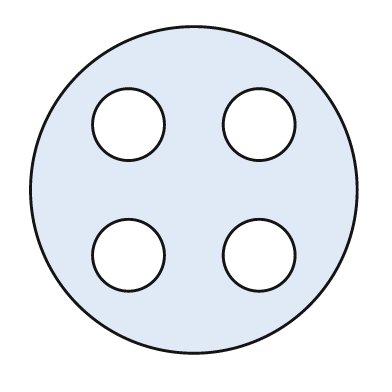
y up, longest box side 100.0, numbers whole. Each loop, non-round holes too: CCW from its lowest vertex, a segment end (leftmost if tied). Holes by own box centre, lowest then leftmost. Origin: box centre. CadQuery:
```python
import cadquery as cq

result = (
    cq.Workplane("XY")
    .moveTo(0.0, 0.0)
    .circle(50.0)
    .moveTo(-20.0, -20.0)
    .circle(11.0)
    .moveTo(20.0, -20.0)
    .circle(11.0)
    .moveTo(-20.0, 20.0)
    .circle(11.0)
    .moveTo(20.0, 20.0)
    .circle(11.0)
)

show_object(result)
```